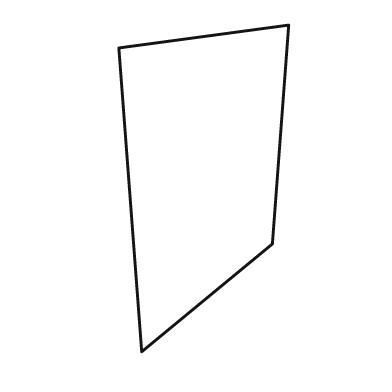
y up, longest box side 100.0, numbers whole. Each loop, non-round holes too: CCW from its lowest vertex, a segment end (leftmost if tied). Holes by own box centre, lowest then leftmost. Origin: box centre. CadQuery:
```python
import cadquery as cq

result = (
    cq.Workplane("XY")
    .moveTo(-19.0, -50.0)
    .lineTo(21.0, -17.0)
    .lineTo(26.0, 50.0)
    .lineTo(-26.0, 43.0)
    .close()
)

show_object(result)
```